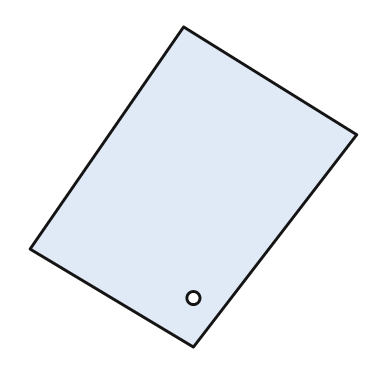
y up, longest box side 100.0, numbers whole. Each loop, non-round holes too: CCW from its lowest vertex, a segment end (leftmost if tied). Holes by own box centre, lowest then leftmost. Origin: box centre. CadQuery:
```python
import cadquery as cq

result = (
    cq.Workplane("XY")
    .moveTo(0.0, -49.0)
    .lineTo(50.0, 16.0)
    .lineTo(-3.0, 49.0)
    .lineTo(-50.0, -19.0)
    .close()
    .moveTo(0.0, -34.0)
    .circle(2.0)
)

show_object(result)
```